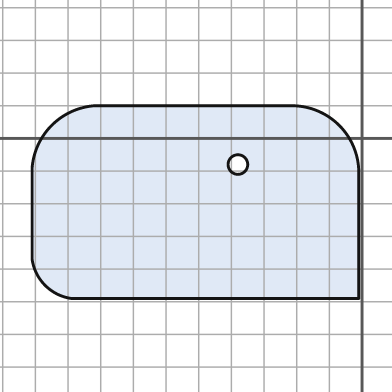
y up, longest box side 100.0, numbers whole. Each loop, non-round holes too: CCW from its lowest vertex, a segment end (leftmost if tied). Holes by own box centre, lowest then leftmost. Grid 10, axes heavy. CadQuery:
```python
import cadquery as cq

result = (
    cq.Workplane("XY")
    .moveTo(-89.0, -49.0)
    .lineTo(-1.0, -49.0)
    .lineTo(-1.0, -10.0)
    .threePointArc((-7.0, 4.0), (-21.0, 10.0))
    .lineTo(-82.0, 10.0)
    .threePointArc((-95.0, 4.0), (-101.0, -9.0))
    .lineTo(-101.0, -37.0)
    .threePointArc((-97.0, -45.0), (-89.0, -49.0))
    .close()
    .moveTo(-38.0, -8.0)
    .circle(3.0)
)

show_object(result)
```